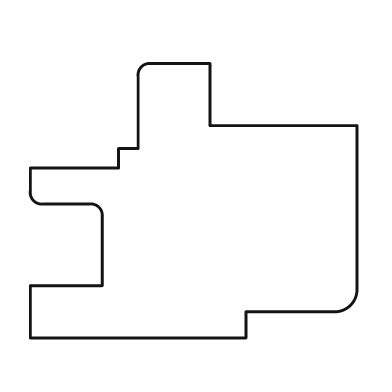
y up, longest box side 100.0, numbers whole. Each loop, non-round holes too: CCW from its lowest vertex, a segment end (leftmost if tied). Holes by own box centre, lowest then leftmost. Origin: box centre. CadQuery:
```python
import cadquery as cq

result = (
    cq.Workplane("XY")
    .moveTo(-50.0, -42.0)
    .lineTo(16.0, -42.0)
    .lineTo(16.0, -34.0)
    .lineTo(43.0, -34.0)
    .threePointArc((48.0, -32.0), (50.0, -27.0))
    .lineTo(50.0, 23.0)
    .lineTo(5.0, 23.0)
    .lineTo(5.0, 42.0)
    .lineTo(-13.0, 42.0)
    .threePointArc((-16.0, 41.0), (-17.0, 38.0))
    .lineTo(-17.0, 16.0)
    .lineTo(-23.0, 16.0)
    .lineTo(-23.0, 10.0)
    .lineTo(-50.0, 10.0)
    .lineTo(-50.0, 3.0)
    .threePointArc((-49.0, 0.0), (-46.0, -1.0))
    .lineTo(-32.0, -1.0)
    .threePointArc((-29.0, -2.0), (-28.0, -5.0))
    .lineTo(-28.0, -26.0)
    .lineTo(-50.0, -26.0)
    .close()
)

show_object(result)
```